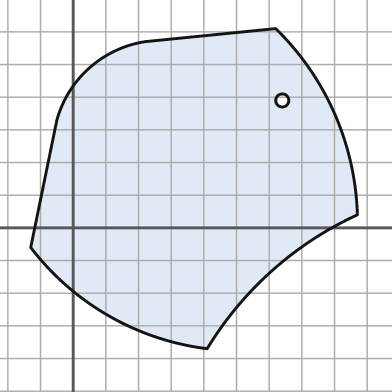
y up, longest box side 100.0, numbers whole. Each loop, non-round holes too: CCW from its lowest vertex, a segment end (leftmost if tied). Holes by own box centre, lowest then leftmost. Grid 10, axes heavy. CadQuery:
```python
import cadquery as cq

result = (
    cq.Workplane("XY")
    .moveTo(41.0, -37.0)
    .threePointArc((61.0, -13.0), (87.0, 4.0))
    .threePointArc((80.0, 35.0), (62.0, 61.0))
    .lineTo(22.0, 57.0)
    .threePointArc((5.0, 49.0), (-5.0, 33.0))
    .lineTo(-13.0, -6.0)
    .threePointArc((11.0, -27.0), (41.0, -37.0))
    .close()
    .moveTo(64.0, 39.0)
    .circle(2.0)
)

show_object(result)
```